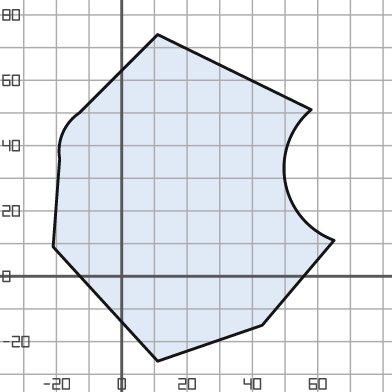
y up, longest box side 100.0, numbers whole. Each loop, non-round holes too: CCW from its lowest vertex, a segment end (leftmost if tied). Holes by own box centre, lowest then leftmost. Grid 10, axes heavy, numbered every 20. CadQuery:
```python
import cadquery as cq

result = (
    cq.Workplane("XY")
    .moveTo(11.0, -26.0)
    .lineTo(43.0, -15.0)
    .lineTo(65.0, 11.0)
    .threePointArc((50.0, 29.0), (58.0, 51.0))
    .lineTo(11.0, 74.0)
    .lineTo(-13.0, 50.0)
    .threePointArc((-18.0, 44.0), (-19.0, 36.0))
    .lineTo(-21.0, 9.0)
    .close()
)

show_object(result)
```